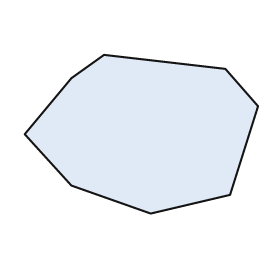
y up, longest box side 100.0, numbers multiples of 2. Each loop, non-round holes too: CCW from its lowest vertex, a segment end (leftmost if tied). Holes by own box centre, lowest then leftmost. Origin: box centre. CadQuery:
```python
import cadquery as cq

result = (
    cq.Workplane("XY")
    .moveTo(4.0, -34.0)
    .lineTo(38.0, -26.0)
    .lineTo(50.0, 12.0)
    .lineTo(36.0, 28.0)
    .lineTo(-16.0, 34.0)
    .lineTo(-30.0, 24.0)
    .lineTo(-50.0, 0.0)
    .lineTo(-30.0, -22.0)
    .close()
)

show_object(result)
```